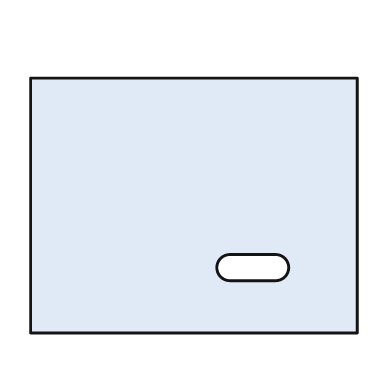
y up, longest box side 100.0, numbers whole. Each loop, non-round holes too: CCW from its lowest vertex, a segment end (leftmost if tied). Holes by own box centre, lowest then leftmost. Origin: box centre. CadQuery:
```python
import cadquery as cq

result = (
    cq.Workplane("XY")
    .moveTo(-50.0, -39.0)
    .lineTo(50.0, -39.0)
    .lineTo(50.0, 39.0)
    .lineTo(-50.0, 39.0)
    .close()
    .moveTo(11.0, -23.0)
    .lineTo(25.0, -23.0)
    .threePointArc((29.0, -19.0), (25.0, -15.0))
    .lineTo(11.0, -15.0)
    .threePointArc((7.0, -19.0), (11.0, -23.0))
    .close()
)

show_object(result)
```